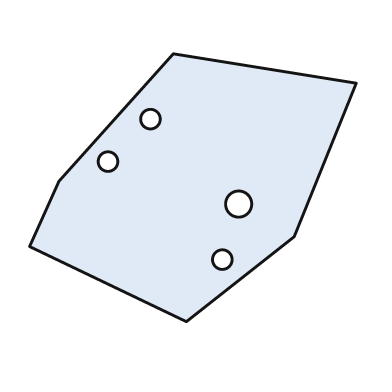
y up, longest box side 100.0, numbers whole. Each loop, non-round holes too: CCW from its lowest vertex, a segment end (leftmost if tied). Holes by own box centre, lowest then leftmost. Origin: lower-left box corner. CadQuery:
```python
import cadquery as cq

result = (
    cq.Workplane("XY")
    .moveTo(48.0, 0.0)
    .lineTo(81.0, 26.0)
    .lineTo(100.0, 73.0)
    .lineTo(44.0, 82.0)
    .lineTo(9.0, 43.0)
    .lineTo(0.0, 23.0)
    .close()
    .moveTo(59.0, 19.0)
    .circle(3.0)
    .moveTo(64.0, 36.0)
    .circle(4.0)
    .moveTo(24.0, 49.0)
    .circle(3.0)
    .moveTo(37.0, 62.0)
    .circle(3.0)
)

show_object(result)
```